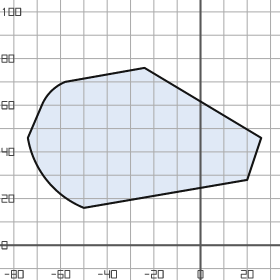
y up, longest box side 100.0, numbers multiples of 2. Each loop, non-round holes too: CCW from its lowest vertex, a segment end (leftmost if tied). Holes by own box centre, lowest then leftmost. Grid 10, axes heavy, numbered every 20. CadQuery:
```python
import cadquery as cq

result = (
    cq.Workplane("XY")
    .moveTo(-50.0, 16.0)
    .lineTo(20.0, 28.0)
    .lineTo(26.0, 46.0)
    .lineTo(-24.0, 76.0)
    .lineTo(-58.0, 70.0)
    .threePointArc((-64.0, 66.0), (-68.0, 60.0))
    .lineTo(-74.0, 46.0)
    .threePointArc((-66.0, 28.0), (-50.0, 16.0))
    .close()
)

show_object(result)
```